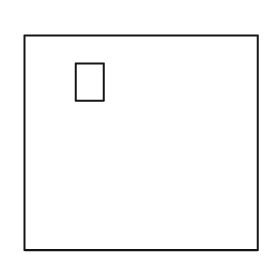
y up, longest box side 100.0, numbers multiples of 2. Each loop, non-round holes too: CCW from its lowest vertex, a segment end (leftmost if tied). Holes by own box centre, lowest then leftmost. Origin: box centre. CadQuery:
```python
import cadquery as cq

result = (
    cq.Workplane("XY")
    .moveTo(-50.0, -46.0)
    .lineTo(50.0, -46.0)
    .lineTo(50.0, 46.0)
    .lineTo(-50.0, 46.0)
    .close()
    .moveTo(-28.0, 18.0)
    .lineTo(-16.0, 18.0)
    .lineTo(-16.0, 34.0)
    .lineTo(-28.0, 34.0)
    .close()
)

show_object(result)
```